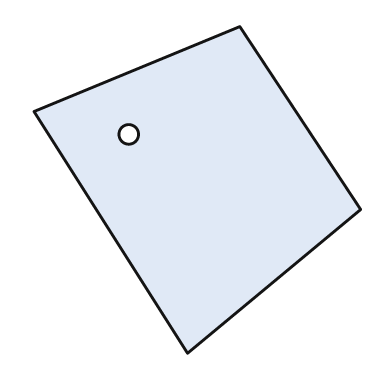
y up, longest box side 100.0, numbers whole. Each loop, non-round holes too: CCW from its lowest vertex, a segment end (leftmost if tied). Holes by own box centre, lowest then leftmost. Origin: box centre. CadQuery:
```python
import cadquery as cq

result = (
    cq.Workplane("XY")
    .moveTo(-3.0, -50.0)
    .lineTo(50.0, -6.0)
    .lineTo(13.0, 50.0)
    .lineTo(-50.0, 24.0)
    .close()
    .moveTo(-21.0, 17.0)
    .circle(3.0)
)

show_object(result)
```